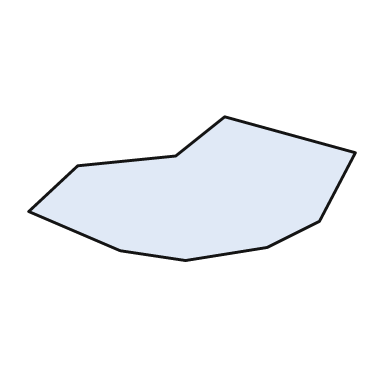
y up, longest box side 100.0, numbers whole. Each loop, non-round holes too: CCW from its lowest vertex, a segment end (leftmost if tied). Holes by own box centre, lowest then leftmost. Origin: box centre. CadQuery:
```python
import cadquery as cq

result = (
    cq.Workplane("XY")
    .moveTo(-2.0, -22.0)
    .lineTo(23.0, -18.0)
    .lineTo(39.0, -10.0)
    .lineTo(50.0, 11.0)
    .lineTo(10.0, 22.0)
    .lineTo(-5.0, 10.0)
    .lineTo(-35.0, 7.0)
    .lineTo(-50.0, -7.0)
    .lineTo(-22.0, -19.0)
    .close()
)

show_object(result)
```